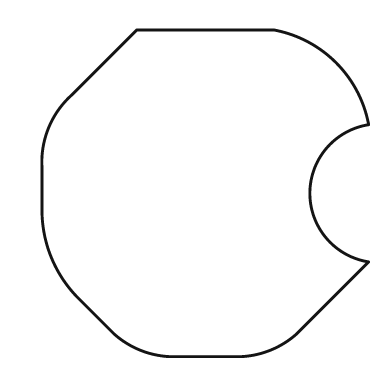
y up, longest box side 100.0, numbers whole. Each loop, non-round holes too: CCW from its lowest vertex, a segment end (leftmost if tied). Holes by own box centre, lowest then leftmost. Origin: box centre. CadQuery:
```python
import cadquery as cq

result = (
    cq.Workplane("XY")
    .moveTo(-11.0, -50.0)
    .lineTo(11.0, -50.0)
    .threePointArc((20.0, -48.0), (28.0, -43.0))
    .lineTo(50.0, -21.0)
    .threePointArc((32.0, 0.0), (50.0, 21.0))
    .threePointArc((40.0, 40.0), (21.0, 50.0))
    .lineTo(-21.0, 50.0)
    .lineTo(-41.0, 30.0)
    .threePointArc((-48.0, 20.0), (-50.0, 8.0))
    .lineTo(-50.0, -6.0)
    .threePointArc((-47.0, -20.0), (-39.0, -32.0))
    .lineTo(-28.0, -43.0)
    .threePointArc((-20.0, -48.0), (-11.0, -50.0))
    .close()
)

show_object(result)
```